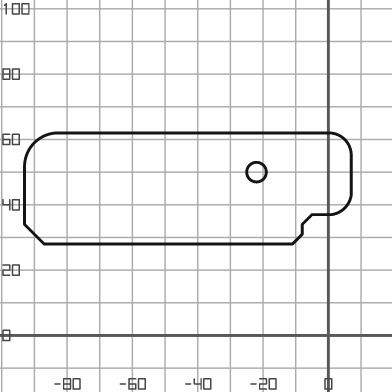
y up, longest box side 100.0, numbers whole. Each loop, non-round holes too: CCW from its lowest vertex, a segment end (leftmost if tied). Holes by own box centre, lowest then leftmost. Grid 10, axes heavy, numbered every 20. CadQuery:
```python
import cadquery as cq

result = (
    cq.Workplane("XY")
    .moveTo(-87.0, 28.0)
    .lineTo(-11.0, 28.0)
    .lineTo(-8.0, 31.0)
    .lineTo(-8.0, 34.0)
    .lineTo(-5.0, 37.0)
    .lineTo(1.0, 37.0)
    .threePointArc((5.0, 39.0), (7.0, 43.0))
    .lineTo(7.0, 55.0)
    .threePointArc((5.0, 60.0), (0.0, 62.0))
    .lineTo(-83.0, 62.0)
    .threePointArc((-90.0, 59.0), (-93.0, 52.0))
    .lineTo(-93.0, 34.0)
    .close()
    .moveTo(-22.0, 50.0)
    .circle(3.0)
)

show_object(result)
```